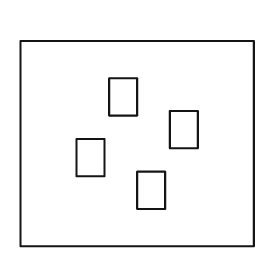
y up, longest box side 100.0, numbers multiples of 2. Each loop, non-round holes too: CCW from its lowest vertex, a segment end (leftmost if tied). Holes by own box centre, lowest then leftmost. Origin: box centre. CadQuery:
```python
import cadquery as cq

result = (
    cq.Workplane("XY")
    .moveTo(-50.0, -44.0)
    .lineTo(50.0, -44.0)
    .lineTo(50.0, 44.0)
    .lineTo(-50.0, 44.0)
    .close()
    .moveTo(0.0, -28.0)
    .lineTo(12.0, -28.0)
    .lineTo(12.0, -12.0)
    .lineTo(0.0, -12.0)
    .close()
    .moveTo(-26.0, -14.0)
    .lineTo(-14.0, -14.0)
    .lineTo(-14.0, 2.0)
    .lineTo(-26.0, 2.0)
    .close()
    .moveTo(14.0, -2.0)
    .lineTo(26.0, -2.0)
    .lineTo(26.0, 14.0)
    .lineTo(14.0, 14.0)
    .close()
    .moveTo(-12.0, 12.0)
    .lineTo(0.0, 12.0)
    .lineTo(0.0, 28.0)
    .lineTo(-12.0, 28.0)
    .close()
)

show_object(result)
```